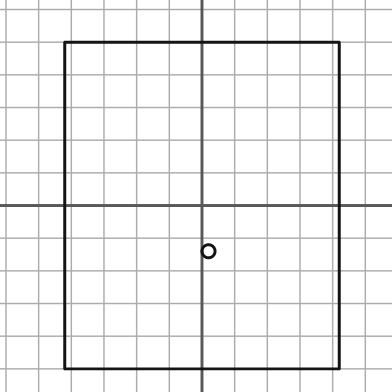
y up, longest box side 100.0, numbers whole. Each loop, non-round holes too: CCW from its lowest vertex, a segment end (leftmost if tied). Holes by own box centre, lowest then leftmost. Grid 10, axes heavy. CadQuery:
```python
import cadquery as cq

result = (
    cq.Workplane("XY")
    .moveTo(-42.0, -50.0)
    .lineTo(42.0, -50.0)
    .lineTo(42.0, 50.0)
    .lineTo(-42.0, 50.0)
    .close()
    .moveTo(2.0, -14.0)
    .circle(2.0)
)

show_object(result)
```